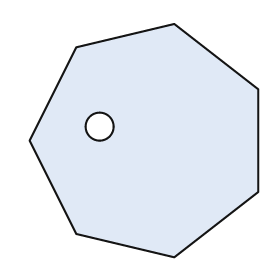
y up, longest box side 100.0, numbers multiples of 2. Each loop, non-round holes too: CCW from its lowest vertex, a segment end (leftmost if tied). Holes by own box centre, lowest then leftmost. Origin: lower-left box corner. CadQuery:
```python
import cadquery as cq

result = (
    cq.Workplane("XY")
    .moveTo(62.0, 0.0)
    .lineTo(98.0, 28.0)
    .lineTo(98.0, 72.0)
    .lineTo(62.0, 100.0)
    .lineTo(20.0, 90.0)
    .lineTo(0.0, 50.0)
    .lineTo(20.0, 10.0)
    .close()
    .moveTo(30.0, 56.0)
    .circle(6.0)
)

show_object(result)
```